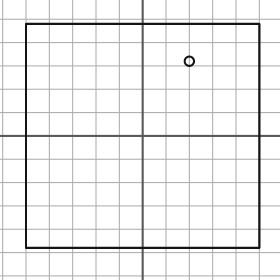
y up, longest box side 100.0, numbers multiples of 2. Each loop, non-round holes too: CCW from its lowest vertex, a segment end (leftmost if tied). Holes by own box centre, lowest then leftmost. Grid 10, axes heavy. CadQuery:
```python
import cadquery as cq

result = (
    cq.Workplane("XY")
    .moveTo(-50.0, -48.0)
    .lineTo(50.0, -48.0)
    .lineTo(50.0, 48.0)
    .lineTo(-50.0, 48.0)
    .close()
    .moveTo(20.0, 32.0)
    .circle(2.0)
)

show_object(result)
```